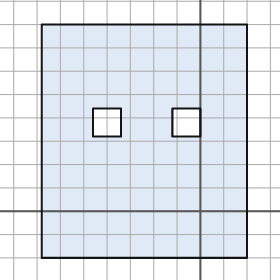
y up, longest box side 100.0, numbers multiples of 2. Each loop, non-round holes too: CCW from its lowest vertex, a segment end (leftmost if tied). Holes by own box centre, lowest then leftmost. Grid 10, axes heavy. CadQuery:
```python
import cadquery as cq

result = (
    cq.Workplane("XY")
    .moveTo(-68.0, -20.0)
    .lineTo(20.0, -20.0)
    .lineTo(20.0, 80.0)
    .lineTo(-68.0, 80.0)
    .close()
    .moveTo(-46.0, 32.0)
    .lineTo(-34.0, 32.0)
    .lineTo(-34.0, 44.0)
    .lineTo(-46.0, 44.0)
    .close()
    .moveTo(-12.0, 32.0)
    .lineTo(0.0, 32.0)
    .lineTo(0.0, 44.0)
    .lineTo(-12.0, 44.0)
    .close()
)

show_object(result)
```